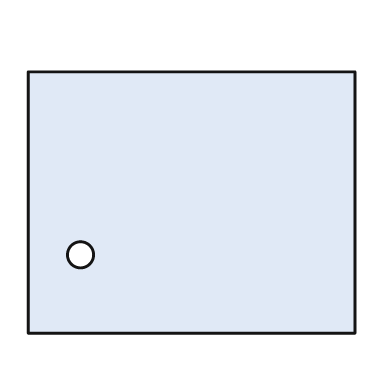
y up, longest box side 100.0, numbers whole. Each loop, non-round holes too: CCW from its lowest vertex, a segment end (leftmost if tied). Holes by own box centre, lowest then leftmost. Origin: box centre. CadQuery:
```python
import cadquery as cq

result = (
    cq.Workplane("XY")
    .moveTo(-50.0, -40.0)
    .lineTo(50.0, -40.0)
    .lineTo(50.0, 40.0)
    .lineTo(-50.0, 40.0)
    .close()
    .moveTo(-34.0, -16.0)
    .circle(4.0)
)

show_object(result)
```